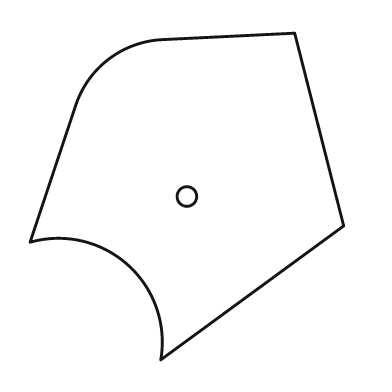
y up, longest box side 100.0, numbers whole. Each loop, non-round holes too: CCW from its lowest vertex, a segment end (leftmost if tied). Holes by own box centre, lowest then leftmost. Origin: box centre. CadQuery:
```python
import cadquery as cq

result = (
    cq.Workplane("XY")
    .moveTo(-8.0, -50.0)
    .lineTo(48.0, -9.0)
    .lineTo(33.0, 50.0)
    .lineTo(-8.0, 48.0)
    .threePointArc((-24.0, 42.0), (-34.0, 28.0))
    .lineTo(-48.0, -14.0)
    .threePointArc((-18.0, -21.0), (-8.0, -50.0))
    .close()
    .moveTo(0.0, 0.0)
    .circle(3.0)
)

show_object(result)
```